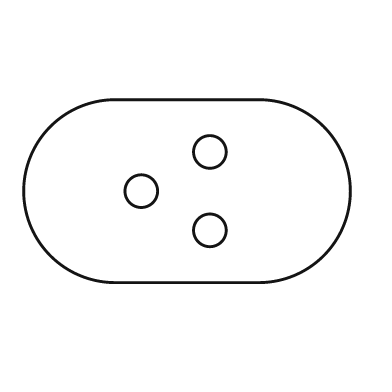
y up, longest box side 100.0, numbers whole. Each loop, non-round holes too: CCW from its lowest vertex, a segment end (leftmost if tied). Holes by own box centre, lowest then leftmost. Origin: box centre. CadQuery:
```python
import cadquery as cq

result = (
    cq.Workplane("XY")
    .moveTo(-22.0, -28.0)
    .lineTo(22.0, -28.0)
    .threePointArc((50.0, 0.0), (22.0, 28.0))
    .lineTo(-22.0, 28.0)
    .threePointArc((-50.0, 0.0), (-22.0, -28.0))
    .close()
    .moveTo(7.0, -12.0)
    .circle(5.0)
    .moveTo(-14.0, 0.0)
    .circle(5.0)
    .moveTo(7.0, 12.0)
    .circle(5.0)
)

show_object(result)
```